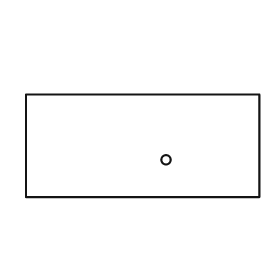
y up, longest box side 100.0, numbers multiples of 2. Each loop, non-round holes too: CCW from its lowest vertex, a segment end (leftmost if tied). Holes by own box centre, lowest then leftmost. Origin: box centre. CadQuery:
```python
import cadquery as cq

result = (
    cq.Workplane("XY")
    .moveTo(-50.0, -22.0)
    .lineTo(50.0, -22.0)
    .lineTo(50.0, 22.0)
    .lineTo(-50.0, 22.0)
    .close()
    .moveTo(10.0, -6.0)
    .circle(2.0)
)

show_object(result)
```